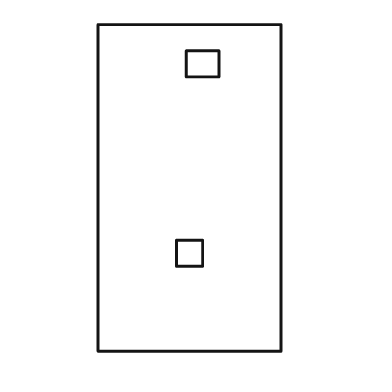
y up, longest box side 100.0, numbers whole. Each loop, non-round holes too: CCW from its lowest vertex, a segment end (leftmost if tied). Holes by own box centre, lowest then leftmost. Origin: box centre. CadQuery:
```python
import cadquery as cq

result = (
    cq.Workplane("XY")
    .moveTo(-28.0, -50.0)
    .lineTo(28.0, -50.0)
    .lineTo(28.0, 50.0)
    .lineTo(-28.0, 50.0)
    .close()
    .moveTo(-4.0, -24.0)
    .lineTo(4.0, -24.0)
    .lineTo(4.0, -16.0)
    .lineTo(-4.0, -16.0)
    .close()
    .moveTo(-1.0, 34.0)
    .lineTo(9.0, 34.0)
    .lineTo(9.0, 42.0)
    .lineTo(-1.0, 42.0)
    .close()
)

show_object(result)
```